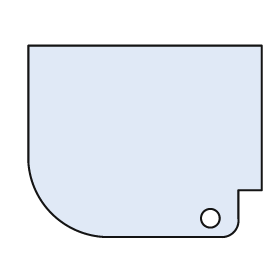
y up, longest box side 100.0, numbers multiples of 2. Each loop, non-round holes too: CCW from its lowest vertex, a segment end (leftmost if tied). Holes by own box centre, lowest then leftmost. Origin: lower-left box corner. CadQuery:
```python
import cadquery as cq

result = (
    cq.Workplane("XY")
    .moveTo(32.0, 0.0)
    .lineTo(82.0, 0.0)
    .threePointArc((88.0, 2.0), (90.0, 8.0))
    .lineTo(90.0, 20.0)
    .lineTo(100.0, 20.0)
    .lineTo(100.0, 82.0)
    .lineTo(0.0, 82.0)
    .lineTo(0.0, 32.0)
    .threePointArc((10.0, 10.0), (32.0, 0.0))
    .close()
    .moveTo(78.0, 8.0)
    .circle(4.0)
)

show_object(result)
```